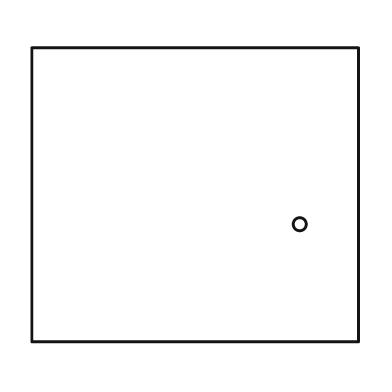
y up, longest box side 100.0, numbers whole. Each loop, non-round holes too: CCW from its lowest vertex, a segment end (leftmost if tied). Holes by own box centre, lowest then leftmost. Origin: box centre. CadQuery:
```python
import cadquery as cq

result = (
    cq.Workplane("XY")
    .moveTo(-50.0, -45.0)
    .lineTo(50.0, -45.0)
    .lineTo(50.0, 45.0)
    .lineTo(-50.0, 45.0)
    .close()
    .moveTo(32.0, -9.0)
    .circle(2.0)
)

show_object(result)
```